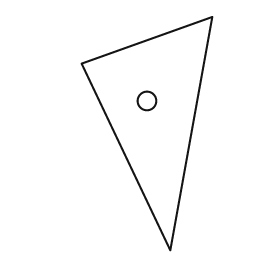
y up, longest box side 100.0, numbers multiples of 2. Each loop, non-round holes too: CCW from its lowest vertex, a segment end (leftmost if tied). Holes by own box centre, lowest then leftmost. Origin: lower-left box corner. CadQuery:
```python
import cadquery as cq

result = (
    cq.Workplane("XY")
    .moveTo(38.0, 0.0)
    .lineTo(56.0, 100.0)
    .lineTo(0.0, 80.0)
    .close()
    .moveTo(28.0, 64.0)
    .circle(4.0)
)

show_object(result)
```